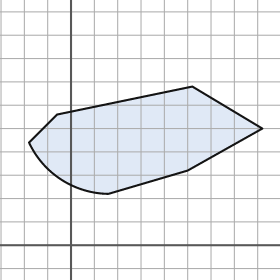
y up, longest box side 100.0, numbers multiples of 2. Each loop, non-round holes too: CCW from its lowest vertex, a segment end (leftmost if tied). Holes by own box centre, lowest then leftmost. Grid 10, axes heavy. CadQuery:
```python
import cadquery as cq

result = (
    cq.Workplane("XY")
    .moveTo(16.0, 22.0)
    .lineTo(50.0, 32.0)
    .lineTo(82.0, 50.0)
    .lineTo(52.0, 68.0)
    .lineTo(-6.0, 56.0)
    .lineTo(-18.0, 44.0)
    .threePointArc((-4.0, 28.0), (16.0, 22.0))
    .close()
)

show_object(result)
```